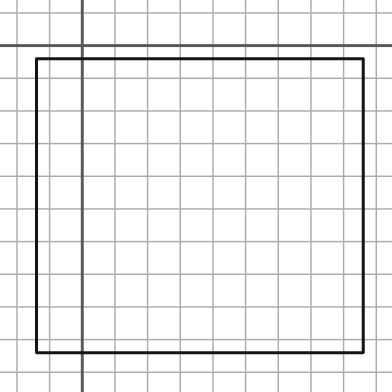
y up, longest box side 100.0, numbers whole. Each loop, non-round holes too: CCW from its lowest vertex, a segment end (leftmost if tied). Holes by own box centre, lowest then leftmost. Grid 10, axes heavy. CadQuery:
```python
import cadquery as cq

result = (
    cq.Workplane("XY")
    .moveTo(-14.0, -94.0)
    .lineTo(86.0, -94.0)
    .lineTo(86.0, -4.0)
    .lineTo(-14.0, -4.0)
    .close()
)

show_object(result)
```